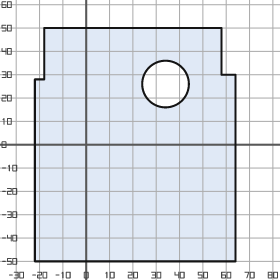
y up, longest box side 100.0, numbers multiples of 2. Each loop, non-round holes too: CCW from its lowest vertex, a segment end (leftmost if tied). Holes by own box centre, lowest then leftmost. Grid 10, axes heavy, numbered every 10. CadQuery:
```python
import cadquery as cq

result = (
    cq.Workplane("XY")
    .moveTo(-22.0, -50.0)
    .lineTo(64.0, -50.0)
    .lineTo(64.0, 30.0)
    .lineTo(58.0, 30.0)
    .lineTo(58.0, 50.0)
    .lineTo(-18.0, 50.0)
    .lineTo(-18.0, 28.0)
    .lineTo(-22.0, 28.0)
    .close()
    .moveTo(34.0, 26.0)
    .circle(10.0)
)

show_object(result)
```